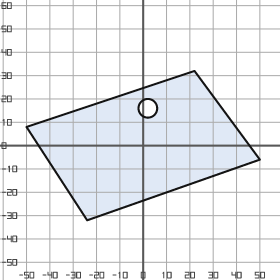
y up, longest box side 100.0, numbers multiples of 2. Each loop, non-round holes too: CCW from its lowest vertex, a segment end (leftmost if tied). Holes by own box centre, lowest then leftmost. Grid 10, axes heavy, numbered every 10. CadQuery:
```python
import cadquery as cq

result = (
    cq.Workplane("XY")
    .moveTo(-24.0, -32.0)
    .lineTo(50.0, -6.0)
    .lineTo(22.0, 32.0)
    .lineTo(-50.0, 8.0)
    .close()
    .moveTo(2.0, 16.0)
    .circle(4.0)
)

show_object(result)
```